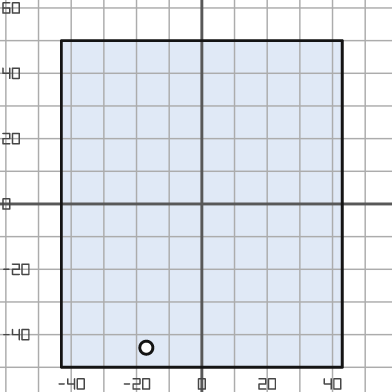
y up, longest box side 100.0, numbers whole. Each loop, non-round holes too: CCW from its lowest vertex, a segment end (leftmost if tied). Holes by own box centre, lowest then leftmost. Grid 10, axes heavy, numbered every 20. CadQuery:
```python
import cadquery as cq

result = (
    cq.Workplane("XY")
    .moveTo(-43.0, -50.0)
    .lineTo(43.0, -50.0)
    .lineTo(43.0, 50.0)
    .lineTo(-43.0, 50.0)
    .close()
    .moveTo(-17.0, -44.0)
    .circle(2.0)
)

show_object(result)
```